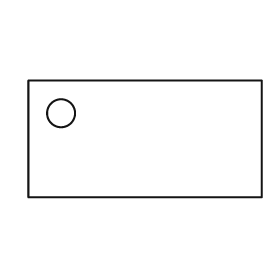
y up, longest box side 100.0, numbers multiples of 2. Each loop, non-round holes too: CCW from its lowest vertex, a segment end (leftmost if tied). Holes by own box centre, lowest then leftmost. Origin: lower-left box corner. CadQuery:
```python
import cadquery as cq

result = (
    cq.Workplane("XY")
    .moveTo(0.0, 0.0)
    .lineTo(100.0, 0.0)
    .lineTo(100.0, 50.0)
    .lineTo(0.0, 50.0)
    .close()
    .moveTo(14.0, 36.0)
    .circle(6.0)
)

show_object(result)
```